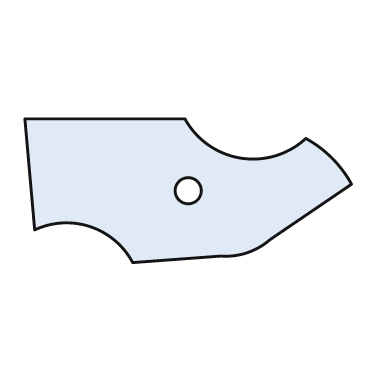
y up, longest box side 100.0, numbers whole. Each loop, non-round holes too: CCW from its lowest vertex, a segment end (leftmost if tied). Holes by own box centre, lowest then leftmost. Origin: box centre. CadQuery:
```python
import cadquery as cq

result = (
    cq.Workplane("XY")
    .moveTo(-17.0, -22.0)
    .lineTo(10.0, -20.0)
    .threePointArc((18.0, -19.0), (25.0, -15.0))
    .lineTo(50.0, 2.0)
    .threePointArc((44.0, 10.0), (36.0, 16.0))
    .threePointArc((16.0, 10.0), (-1.0, 22.0))
    .lineTo(-50.0, 22.0)
    .lineTo(-47.0, -12.0)
    .threePointArc((-30.0, -11.0), (-17.0, -22.0))
    .close()
    .moveTo(0.0, 0.0)
    .circle(4.0)
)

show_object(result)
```